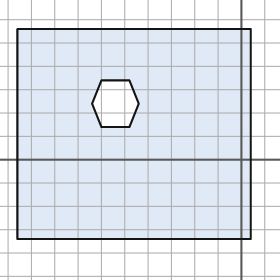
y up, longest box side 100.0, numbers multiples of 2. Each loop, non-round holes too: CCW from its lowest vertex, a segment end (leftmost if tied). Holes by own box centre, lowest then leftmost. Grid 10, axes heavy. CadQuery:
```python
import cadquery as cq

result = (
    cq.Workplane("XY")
    .moveTo(-96.0, -34.0)
    .lineTo(4.0, -34.0)
    .lineTo(4.0, 56.0)
    .lineTo(-96.0, 56.0)
    .close()
    .moveTo(-60.0, 14.0)
    .lineTo(-48.0, 14.0)
    .lineTo(-44.0, 24.0)
    .lineTo(-48.0, 34.0)
    .lineTo(-60.0, 34.0)
    .lineTo(-64.0, 24.0)
    .close()
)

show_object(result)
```